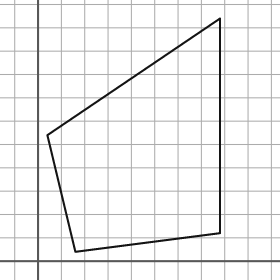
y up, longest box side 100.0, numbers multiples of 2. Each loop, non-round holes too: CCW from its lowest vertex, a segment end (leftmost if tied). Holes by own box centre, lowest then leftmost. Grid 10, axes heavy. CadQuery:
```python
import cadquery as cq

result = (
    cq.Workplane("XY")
    .moveTo(16.0, 4.0)
    .lineTo(78.0, 12.0)
    .lineTo(78.0, 104.0)
    .lineTo(4.0, 54.0)
    .close()
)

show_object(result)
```